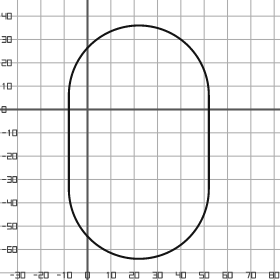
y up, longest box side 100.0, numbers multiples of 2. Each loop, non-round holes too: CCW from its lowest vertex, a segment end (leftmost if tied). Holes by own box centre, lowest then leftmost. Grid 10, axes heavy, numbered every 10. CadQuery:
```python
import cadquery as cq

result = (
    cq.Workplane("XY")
    .moveTo(-8.0, -34.0)
    .threePointArc((22.0, -64.0), (52.0, -34.0))
    .lineTo(52.0, 6.0)
    .threePointArc((22.0, 36.0), (-8.0, 6.0))
    .close()
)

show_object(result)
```